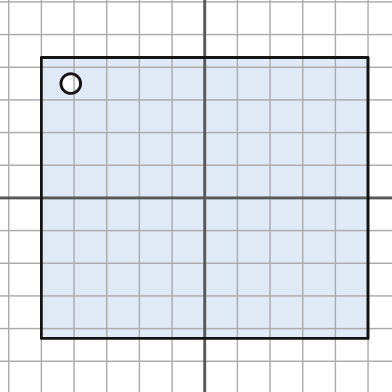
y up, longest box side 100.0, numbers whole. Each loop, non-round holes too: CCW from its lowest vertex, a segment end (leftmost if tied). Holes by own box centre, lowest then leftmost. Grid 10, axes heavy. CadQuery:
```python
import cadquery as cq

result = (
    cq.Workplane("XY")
    .moveTo(-50.0, -43.0)
    .lineTo(50.0, -43.0)
    .lineTo(50.0, 43.0)
    .lineTo(-50.0, 43.0)
    .close()
    .moveTo(-41.0, 35.0)
    .circle(3.0)
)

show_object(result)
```